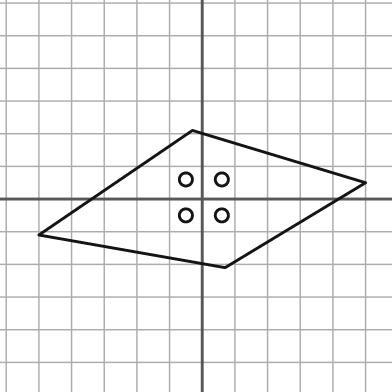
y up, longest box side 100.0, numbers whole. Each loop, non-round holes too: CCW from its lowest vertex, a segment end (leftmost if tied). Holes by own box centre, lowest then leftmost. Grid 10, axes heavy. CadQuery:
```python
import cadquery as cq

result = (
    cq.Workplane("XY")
    .moveTo(7.0, -21.0)
    .lineTo(50.0, 5.0)
    .lineTo(-3.0, 21.0)
    .lineTo(-50.0, -11.0)
    .close()
    .moveTo(-5.0, -5.0)
    .circle(2.0)
    .moveTo(6.0, -5.0)
    .circle(2.0)
    .moveTo(-5.0, 6.0)
    .circle(2.0)
    .moveTo(6.0, 6.0)
    .circle(2.0)
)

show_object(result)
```